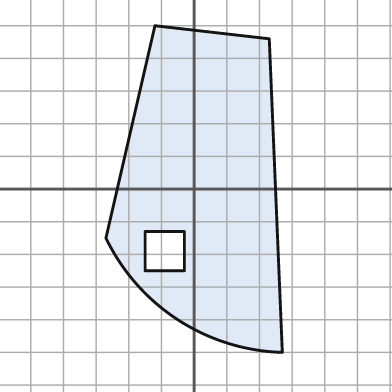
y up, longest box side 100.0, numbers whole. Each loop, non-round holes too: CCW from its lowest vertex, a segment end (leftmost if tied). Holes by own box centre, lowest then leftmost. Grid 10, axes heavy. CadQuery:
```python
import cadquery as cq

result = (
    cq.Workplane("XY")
    .moveTo(27.0, -50.0)
    .lineTo(23.0, 46.0)
    .lineTo(-12.0, 50.0)
    .lineTo(-27.0, -15.0)
    .threePointArc((-5.0, -40.0), (27.0, -50.0))
    .close()
    .moveTo(-15.0, -25.0)
    .lineTo(-3.0, -25.0)
    .lineTo(-3.0, -13.0)
    .lineTo(-15.0, -13.0)
    .close()
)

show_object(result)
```